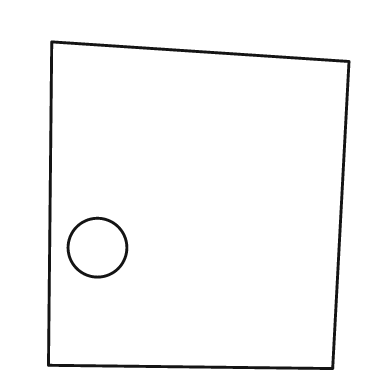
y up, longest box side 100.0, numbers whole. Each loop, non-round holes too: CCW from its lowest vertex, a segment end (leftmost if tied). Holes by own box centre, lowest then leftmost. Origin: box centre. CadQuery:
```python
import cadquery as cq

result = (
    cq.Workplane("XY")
    .moveTo(41.0, -50.0)
    .lineTo(46.0, 44.0)
    .lineTo(-45.0, 50.0)
    .lineTo(-46.0, -49.0)
    .close()
    .moveTo(-31.0, -13.0)
    .circle(9.0)
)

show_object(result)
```